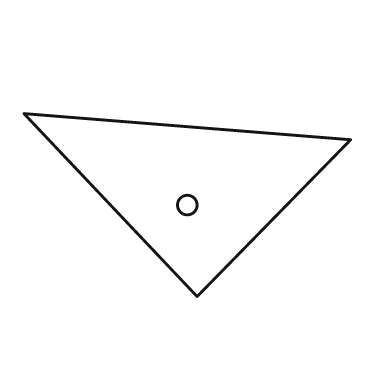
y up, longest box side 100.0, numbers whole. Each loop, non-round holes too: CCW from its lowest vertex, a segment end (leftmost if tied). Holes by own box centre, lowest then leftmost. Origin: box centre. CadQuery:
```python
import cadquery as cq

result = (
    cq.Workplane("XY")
    .moveTo(3.0, -28.0)
    .lineTo(50.0, 20.0)
    .lineTo(-50.0, 28.0)
    .close()
    .moveTo(0.0, 0.0)
    .circle(3.0)
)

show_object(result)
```